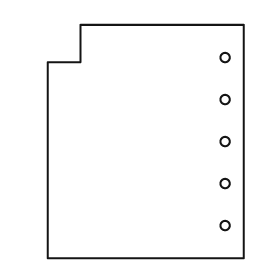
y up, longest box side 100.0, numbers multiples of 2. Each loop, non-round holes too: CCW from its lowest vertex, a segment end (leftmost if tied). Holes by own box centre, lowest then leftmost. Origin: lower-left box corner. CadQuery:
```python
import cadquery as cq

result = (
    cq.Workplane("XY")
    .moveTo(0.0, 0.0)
    .lineTo(84.0, 0.0)
    .lineTo(84.0, 100.0)
    .lineTo(14.0, 100.0)
    .lineTo(14.0, 84.0)
    .lineTo(0.0, 84.0)
    .close()
    .moveTo(76.0, 14.0)
    .circle(2.0)
    .moveTo(76.0, 32.0)
    .circle(2.0)
    .moveTo(76.0, 50.0)
    .circle(2.0)
    .moveTo(76.0, 68.0)
    .circle(2.0)
    .moveTo(76.0, 86.0)
    .circle(2.0)
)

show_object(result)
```